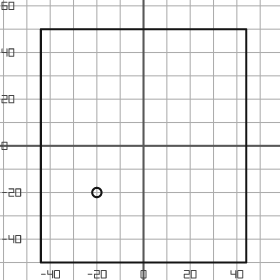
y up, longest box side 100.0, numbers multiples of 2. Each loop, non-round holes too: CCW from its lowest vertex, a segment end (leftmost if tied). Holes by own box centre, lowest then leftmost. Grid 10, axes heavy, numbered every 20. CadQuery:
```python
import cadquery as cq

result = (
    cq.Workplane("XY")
    .moveTo(-44.0, -50.0)
    .lineTo(44.0, -50.0)
    .lineTo(44.0, 50.0)
    .lineTo(-44.0, 50.0)
    .close()
    .moveTo(-20.0, -20.0)
    .circle(2.0)
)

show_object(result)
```